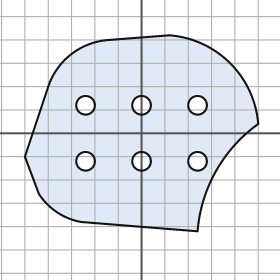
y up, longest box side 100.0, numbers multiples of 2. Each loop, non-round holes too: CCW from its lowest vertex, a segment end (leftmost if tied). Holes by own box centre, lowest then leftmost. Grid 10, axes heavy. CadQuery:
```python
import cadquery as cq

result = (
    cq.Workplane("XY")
    .moveTo(24.0, -42.0)
    .threePointArc((32.0, -16.0), (50.0, 4.0))
    .threePointArc((38.0, 30.0), (12.0, 42.0))
    .lineTo(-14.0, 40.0)
    .threePointArc((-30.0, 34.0), (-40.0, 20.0))
    .lineTo(-50.0, -10.0)
    .lineTo(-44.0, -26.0)
    .threePointArc((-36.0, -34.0), (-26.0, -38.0))
    .close()
    .moveTo(-24.0, -12.0)
    .circle(4.0)
    .moveTo(0.0, -12.0)
    .circle(4.0)
    .moveTo(24.0, -12.0)
    .circle(4.0)
    .moveTo(-24.0, 12.0)
    .circle(4.0)
    .moveTo(0.0, 12.0)
    .circle(4.0)
    .moveTo(24.0, 12.0)
    .circle(4.0)
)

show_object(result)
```